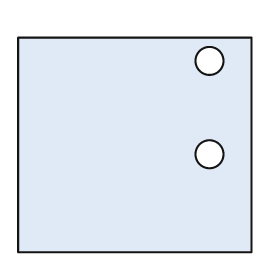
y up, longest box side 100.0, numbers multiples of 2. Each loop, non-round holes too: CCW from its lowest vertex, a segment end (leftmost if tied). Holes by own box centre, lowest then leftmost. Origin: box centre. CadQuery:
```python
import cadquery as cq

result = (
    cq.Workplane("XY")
    .moveTo(-50.0, -46.0)
    .lineTo(50.0, -46.0)
    .lineTo(50.0, 46.0)
    .lineTo(-50.0, 46.0)
    .close()
    .moveTo(32.0, -4.0)
    .circle(6.0)
    .moveTo(32.0, 36.0)
    .circle(6.0)
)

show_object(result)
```